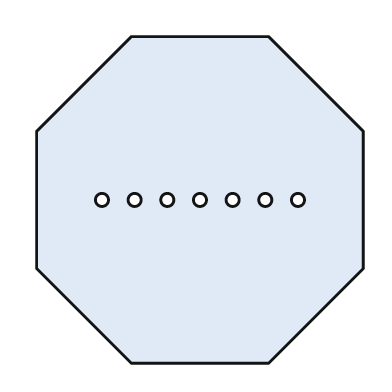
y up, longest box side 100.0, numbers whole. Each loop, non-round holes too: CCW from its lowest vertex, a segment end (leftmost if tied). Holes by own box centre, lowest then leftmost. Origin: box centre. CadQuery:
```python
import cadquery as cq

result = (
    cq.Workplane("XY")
    .moveTo(-21.0, -50.0)
    .lineTo(21.0, -50.0)
    .lineTo(50.0, -21.0)
    .lineTo(50.0, 21.0)
    .lineTo(21.0, 50.0)
    .lineTo(-21.0, 50.0)
    .lineTo(-50.0, 21.0)
    .lineTo(-50.0, -21.0)
    .close()
    .moveTo(-30.0, 0.0)
    .circle(2.0)
    .moveTo(-20.0, 0.0)
    .circle(2.0)
    .moveTo(-10.0, 0.0)
    .circle(2.0)
    .moveTo(0.0, 0.0)
    .circle(2.0)
    .moveTo(10.0, 0.0)
    .circle(2.0)
    .moveTo(20.0, 0.0)
    .circle(2.0)
    .moveTo(30.0, 0.0)
    .circle(2.0)
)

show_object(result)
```